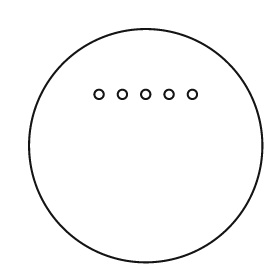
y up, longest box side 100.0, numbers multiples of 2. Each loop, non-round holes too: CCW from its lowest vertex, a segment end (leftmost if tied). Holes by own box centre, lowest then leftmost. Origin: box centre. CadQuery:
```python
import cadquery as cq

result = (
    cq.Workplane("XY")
    .moveTo(0.0, 0.0)
    .circle(50.0)
    .moveTo(-20.0, 22.0)
    .circle(2.0)
    .moveTo(-10.0, 22.0)
    .circle(2.0)
    .moveTo(0.0, 22.0)
    .circle(2.0)
    .moveTo(10.0, 22.0)
    .circle(2.0)
    .moveTo(20.0, 22.0)
    .circle(2.0)
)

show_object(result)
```